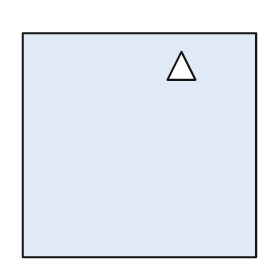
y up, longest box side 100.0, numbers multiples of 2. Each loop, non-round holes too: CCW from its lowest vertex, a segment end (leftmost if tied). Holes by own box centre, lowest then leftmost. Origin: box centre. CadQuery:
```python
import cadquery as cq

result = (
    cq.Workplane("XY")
    .moveTo(-50.0, -48.0)
    .lineTo(50.0, -48.0)
    .lineTo(50.0, 48.0)
    .lineTo(-50.0, 48.0)
    .close()
    .moveTo(12.0, 28.0)
    .lineTo(24.0, 28.0)
    .lineTo(18.0, 40.0)
    .close()
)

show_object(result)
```